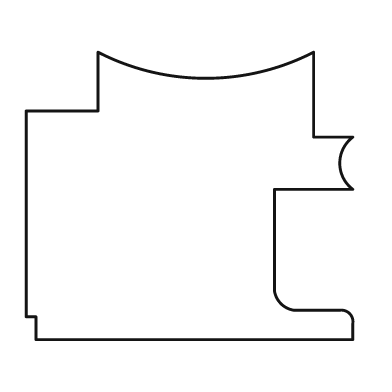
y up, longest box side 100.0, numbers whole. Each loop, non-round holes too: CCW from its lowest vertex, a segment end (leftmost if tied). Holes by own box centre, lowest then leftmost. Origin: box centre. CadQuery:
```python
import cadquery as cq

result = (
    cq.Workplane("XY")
    .moveTo(-47.0, -44.0)
    .lineTo(50.0, -44.0)
    .lineTo(50.0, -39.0)
    .threePointArc((49.0, -36.0), (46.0, -35.0))
    .lineTo(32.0, -35.0)
    .threePointArc((28.0, -33.0), (26.0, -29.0))
    .lineTo(26.0, 2.0)
    .lineTo(50.0, 2.0)
    .threePointArc((46.0, 10.0), (50.0, 18.0))
    .lineTo(38.0, 18.0)
    .lineTo(38.0, 44.0)
    .threePointArc((5.0, 36.0), (-28.0, 44.0))
    .lineTo(-28.0, 26.0)
    .lineTo(-50.0, 26.0)
    .lineTo(-50.0, -37.0)
    .lineTo(-47.0, -37.0)
    .close()
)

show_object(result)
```